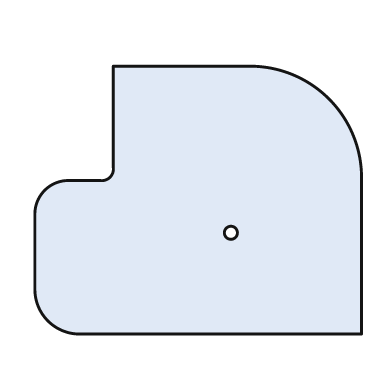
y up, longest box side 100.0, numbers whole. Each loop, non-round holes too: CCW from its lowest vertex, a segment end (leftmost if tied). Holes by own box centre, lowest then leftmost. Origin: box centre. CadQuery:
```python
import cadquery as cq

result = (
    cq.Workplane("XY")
    .moveTo(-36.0, -41.0)
    .lineTo(50.0, -41.0)
    .lineTo(50.0, 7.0)
    .threePointArc((40.0, 31.0), (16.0, 41.0))
    .lineTo(-26.0, 41.0)
    .lineTo(-26.0, 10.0)
    .threePointArc((-27.0, 7.0), (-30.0, 6.0))
    .lineTo(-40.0, 6.0)
    .threePointArc((-47.0, 3.0), (-50.0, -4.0))
    .lineTo(-50.0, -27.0)
    .threePointArc((-46.0, -37.0), (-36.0, -41.0))
    .close()
    .moveTo(10.0, -10.0)
    .circle(2.0)
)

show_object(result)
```